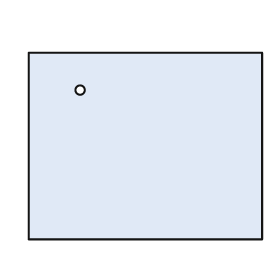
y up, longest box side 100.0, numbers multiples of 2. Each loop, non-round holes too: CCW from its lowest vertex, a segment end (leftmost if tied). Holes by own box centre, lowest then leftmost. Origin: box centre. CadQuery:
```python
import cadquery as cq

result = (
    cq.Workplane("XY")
    .moveTo(-50.0, -40.0)
    .lineTo(50.0, -40.0)
    .lineTo(50.0, 40.0)
    .lineTo(-50.0, 40.0)
    .close()
    .moveTo(-28.0, 24.0)
    .circle(2.0)
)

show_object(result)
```